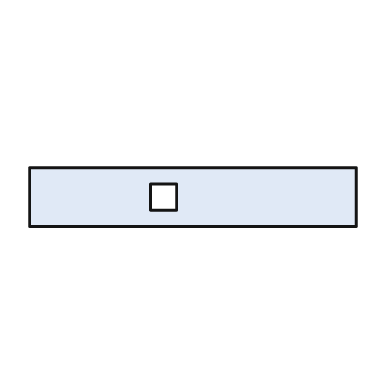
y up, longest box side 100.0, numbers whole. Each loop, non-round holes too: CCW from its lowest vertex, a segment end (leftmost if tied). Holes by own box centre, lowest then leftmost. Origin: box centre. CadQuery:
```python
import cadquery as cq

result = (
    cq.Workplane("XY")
    .moveTo(-50.0, -9.0)
    .lineTo(50.0, -9.0)
    .lineTo(50.0, 9.0)
    .lineTo(-50.0, 9.0)
    .close()
    .moveTo(-13.0, -4.0)
    .lineTo(-5.0, -4.0)
    .lineTo(-5.0, 4.0)
    .lineTo(-13.0, 4.0)
    .close()
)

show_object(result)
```